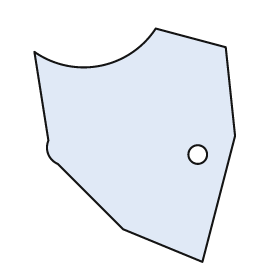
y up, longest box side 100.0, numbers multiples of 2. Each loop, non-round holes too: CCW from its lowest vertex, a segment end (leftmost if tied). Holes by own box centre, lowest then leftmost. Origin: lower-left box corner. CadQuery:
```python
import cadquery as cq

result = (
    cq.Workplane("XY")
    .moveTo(72.0, 0.0)
    .lineTo(86.0, 54.0)
    .lineTo(82.0, 92.0)
    .lineTo(52.0, 100.0)
    .threePointArc((28.0, 84.0), (0.0, 90.0))
    .lineTo(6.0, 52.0)
    .threePointArc((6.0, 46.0), (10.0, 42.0))
    .lineTo(38.0, 14.0)
    .close()
    .moveTo(70.0, 46.0)
    .circle(4.0)
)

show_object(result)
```